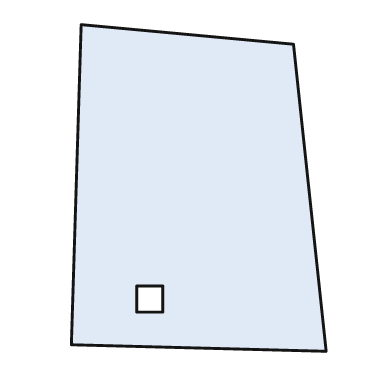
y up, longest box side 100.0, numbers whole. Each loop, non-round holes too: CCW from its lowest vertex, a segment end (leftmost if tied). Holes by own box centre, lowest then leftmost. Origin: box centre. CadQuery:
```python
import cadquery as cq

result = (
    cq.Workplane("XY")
    .moveTo(39.0, -50.0)
    .lineTo(29.0, 44.0)
    .lineTo(-36.0, 50.0)
    .lineTo(-39.0, -48.0)
    .close()
    .moveTo(-19.0, -38.0)
    .lineTo(-11.0, -38.0)
    .lineTo(-11.0, -30.0)
    .lineTo(-19.0, -30.0)
    .close()
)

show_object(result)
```